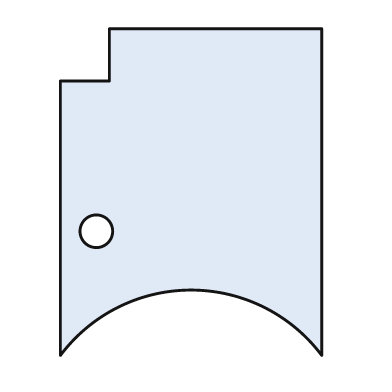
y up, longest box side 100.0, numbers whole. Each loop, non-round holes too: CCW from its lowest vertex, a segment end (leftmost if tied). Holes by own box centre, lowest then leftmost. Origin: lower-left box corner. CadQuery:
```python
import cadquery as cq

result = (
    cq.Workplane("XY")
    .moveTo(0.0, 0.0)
    .threePointArc((40.0, 20.0), (80.0, 0.0))
    .lineTo(80.0, 100.0)
    .lineTo(15.0, 100.0)
    .lineTo(15.0, 84.0)
    .lineTo(0.0, 84.0)
    .close()
    .moveTo(11.0, 38.0)
    .circle(5.0)
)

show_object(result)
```